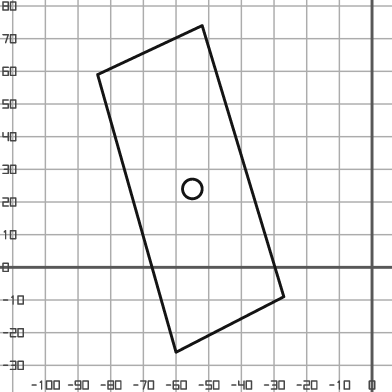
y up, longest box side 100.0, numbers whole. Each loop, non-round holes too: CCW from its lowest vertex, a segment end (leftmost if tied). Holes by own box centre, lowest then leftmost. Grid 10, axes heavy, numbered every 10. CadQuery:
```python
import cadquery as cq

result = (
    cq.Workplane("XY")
    .moveTo(-60.0, -26.0)
    .lineTo(-27.0, -9.0)
    .lineTo(-52.0, 74.0)
    .lineTo(-84.0, 59.0)
    .close()
    .moveTo(-55.0, 24.0)
    .circle(3.0)
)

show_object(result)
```